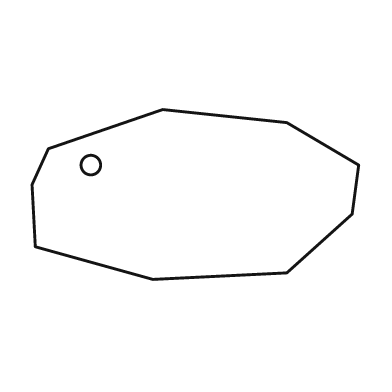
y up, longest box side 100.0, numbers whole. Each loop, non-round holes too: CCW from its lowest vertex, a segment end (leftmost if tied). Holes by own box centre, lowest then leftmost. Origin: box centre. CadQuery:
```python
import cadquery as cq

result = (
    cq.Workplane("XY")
    .moveTo(-13.0, -26.0)
    .lineTo(28.0, -24.0)
    .lineTo(48.0, -6.0)
    .lineTo(50.0, 9.0)
    .lineTo(28.0, 22.0)
    .lineTo(-10.0, 26.0)
    .lineTo(-45.0, 14.0)
    .lineTo(-50.0, 3.0)
    .lineTo(-49.0, -16.0)
    .close()
    .moveTo(-32.0, 9.0)
    .circle(3.0)
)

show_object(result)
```